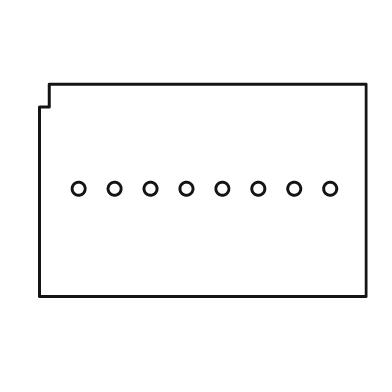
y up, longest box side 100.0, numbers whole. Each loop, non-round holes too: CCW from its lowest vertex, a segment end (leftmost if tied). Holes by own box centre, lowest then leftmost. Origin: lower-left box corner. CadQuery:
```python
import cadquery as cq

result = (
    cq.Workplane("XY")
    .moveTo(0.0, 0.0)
    .lineTo(100.0, 0.0)
    .lineTo(100.0, 65.0)
    .lineTo(3.0, 65.0)
    .lineTo(3.0, 58.0)
    .lineTo(0.0, 58.0)
    .close()
    .moveTo(12.0, 33.0)
    .circle(2.0)
    .moveTo(23.0, 33.0)
    .circle(2.0)
    .moveTo(34.0, 33.0)
    .circle(2.0)
    .moveTo(45.0, 33.0)
    .circle(2.0)
    .moveTo(56.0, 33.0)
    .circle(2.0)
    .moveTo(67.0, 33.0)
    .circle(2.0)
    .moveTo(78.0, 33.0)
    .circle(2.0)
    .moveTo(89.0, 33.0)
    .circle(2.0)
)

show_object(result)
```